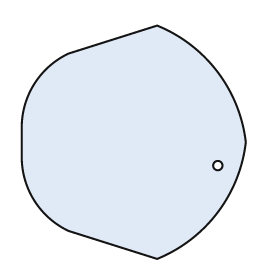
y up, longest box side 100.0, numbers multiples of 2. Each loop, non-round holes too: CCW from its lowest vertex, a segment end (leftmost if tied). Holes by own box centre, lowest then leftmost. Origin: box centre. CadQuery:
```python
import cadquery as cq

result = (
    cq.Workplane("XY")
    .moveTo(10.0, -50.0)
    .threePointArc((36.0, -30.0), (48.0, 0.0))
    .threePointArc((36.0, 30.0), (10.0, 50.0))
    .lineTo(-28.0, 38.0)
    .threePointArc((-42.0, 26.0), (-48.0, 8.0))
    .lineTo(-48.0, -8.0)
    .threePointArc((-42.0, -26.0), (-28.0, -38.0))
    .close()
    .moveTo(36.0, -10.0)
    .circle(2.0)
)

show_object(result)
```